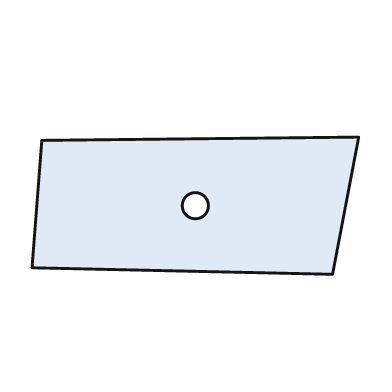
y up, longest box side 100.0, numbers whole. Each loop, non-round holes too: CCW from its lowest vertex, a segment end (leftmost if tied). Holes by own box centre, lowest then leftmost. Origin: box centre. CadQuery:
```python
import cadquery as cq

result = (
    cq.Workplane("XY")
    .moveTo(42.0, -21.0)
    .lineTo(50.0, 21.0)
    .lineTo(-47.0, 20.0)
    .lineTo(-50.0, -19.0)
    .close()
    .moveTo(0.0, 0.0)
    .circle(4.0)
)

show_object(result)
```